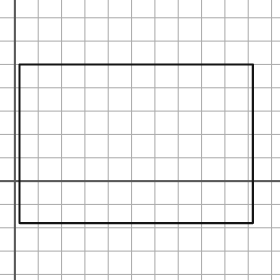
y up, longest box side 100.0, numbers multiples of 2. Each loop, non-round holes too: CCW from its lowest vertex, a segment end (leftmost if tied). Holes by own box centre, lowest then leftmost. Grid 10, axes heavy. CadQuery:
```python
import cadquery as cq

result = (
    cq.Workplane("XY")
    .moveTo(2.0, -18.0)
    .lineTo(102.0, -18.0)
    .lineTo(102.0, 50.0)
    .lineTo(2.0, 50.0)
    .close()
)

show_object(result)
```